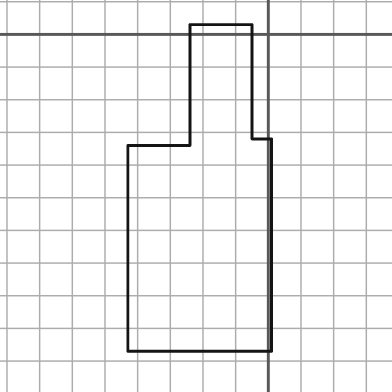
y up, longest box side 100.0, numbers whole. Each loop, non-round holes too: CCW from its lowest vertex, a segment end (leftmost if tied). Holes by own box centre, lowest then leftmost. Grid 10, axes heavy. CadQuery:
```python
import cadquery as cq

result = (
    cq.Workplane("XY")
    .moveTo(-43.0, -97.0)
    .lineTo(1.0, -97.0)
    .lineTo(1.0, -32.0)
    .lineTo(-5.0, -32.0)
    .lineTo(-5.0, 3.0)
    .lineTo(-24.0, 3.0)
    .lineTo(-24.0, -34.0)
    .lineTo(-43.0, -34.0)
    .close()
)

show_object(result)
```